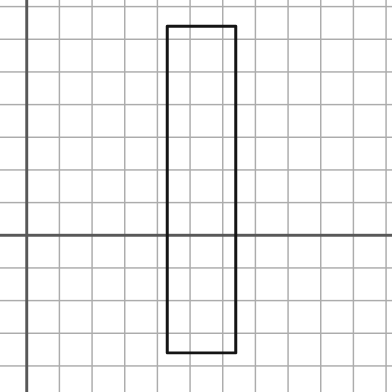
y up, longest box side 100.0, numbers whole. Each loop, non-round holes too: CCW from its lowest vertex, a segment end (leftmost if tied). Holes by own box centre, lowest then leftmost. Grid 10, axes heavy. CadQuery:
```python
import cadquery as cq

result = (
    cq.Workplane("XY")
    .moveTo(43.0, -36.0)
    .lineTo(64.0, -36.0)
    .lineTo(64.0, 64.0)
    .lineTo(43.0, 64.0)
    .close()
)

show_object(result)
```